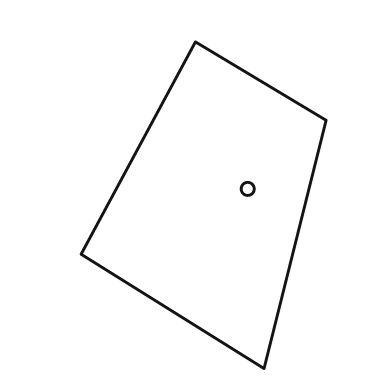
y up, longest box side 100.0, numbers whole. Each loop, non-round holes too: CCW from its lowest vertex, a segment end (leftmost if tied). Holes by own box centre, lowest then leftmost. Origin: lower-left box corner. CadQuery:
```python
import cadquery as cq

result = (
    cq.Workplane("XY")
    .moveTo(56.0, 0.0)
    .lineTo(75.0, 76.0)
    .lineTo(35.0, 100.0)
    .lineTo(0.0, 35.0)
    .close()
    .moveTo(51.0, 55.0)
    .circle(2.0)
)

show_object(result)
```